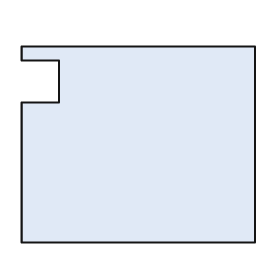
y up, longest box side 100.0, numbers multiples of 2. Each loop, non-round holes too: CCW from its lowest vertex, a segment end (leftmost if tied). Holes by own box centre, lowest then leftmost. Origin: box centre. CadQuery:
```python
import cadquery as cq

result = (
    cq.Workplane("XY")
    .moveTo(-50.0, -42.0)
    .lineTo(50.0, -42.0)
    .lineTo(50.0, 42.0)
    .lineTo(-50.0, 42.0)
    .lineTo(-50.0, 36.0)
    .lineTo(-34.0, 36.0)
    .lineTo(-34.0, 18.0)
    .lineTo(-50.0, 18.0)
    .close()
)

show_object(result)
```